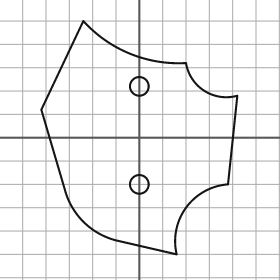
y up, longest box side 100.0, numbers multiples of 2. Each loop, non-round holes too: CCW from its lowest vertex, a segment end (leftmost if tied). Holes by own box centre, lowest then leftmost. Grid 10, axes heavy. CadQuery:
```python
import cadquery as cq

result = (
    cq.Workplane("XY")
    .moveTo(16.0, -50.0)
    .threePointArc((20.0, -30.0), (38.0, -20.0))
    .lineTo(42.0, 18.0)
    .threePointArc((28.0, 20.0), (20.0, 32.0))
    .threePointArc((-4.0, 36.0), (-24.0, 50.0))
    .lineTo(-42.0, 12.0)
    .lineTo(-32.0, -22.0)
    .threePointArc((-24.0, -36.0), (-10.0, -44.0))
    .close()
    .moveTo(0.0, -20.0)
    .circle(4.0)
    .moveTo(0.0, 22.0)
    .circle(4.0)
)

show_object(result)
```